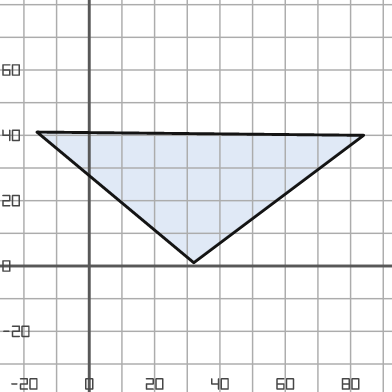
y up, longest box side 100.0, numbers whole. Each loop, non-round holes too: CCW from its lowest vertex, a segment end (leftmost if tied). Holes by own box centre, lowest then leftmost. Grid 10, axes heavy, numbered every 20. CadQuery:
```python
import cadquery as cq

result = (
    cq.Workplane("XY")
    .moveTo(32.0, 1.0)
    .lineTo(84.0, 40.0)
    .lineTo(-16.0, 41.0)
    .close()
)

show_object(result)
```